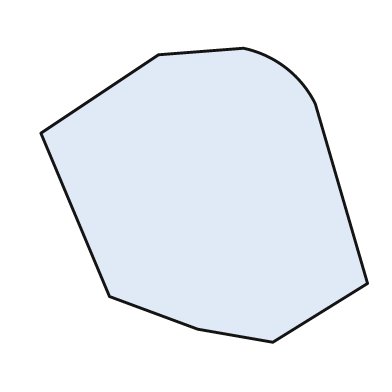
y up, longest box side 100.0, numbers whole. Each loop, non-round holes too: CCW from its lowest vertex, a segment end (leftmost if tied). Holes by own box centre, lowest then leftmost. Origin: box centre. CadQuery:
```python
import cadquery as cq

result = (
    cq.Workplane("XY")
    .moveTo(21.0, -45.0)
    .lineTo(50.0, -27.0)
    .lineTo(34.0, 28.0)
    .threePointArc((25.0, 39.0), (12.0, 45.0))
    .lineTo(-14.0, 43.0)
    .lineTo(-50.0, 19.0)
    .lineTo(-29.0, -31.0)
    .lineTo(-2.0, -41.0)
    .close()
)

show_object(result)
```